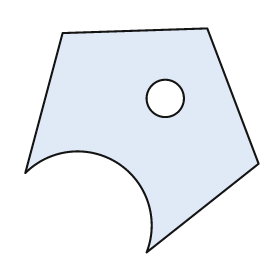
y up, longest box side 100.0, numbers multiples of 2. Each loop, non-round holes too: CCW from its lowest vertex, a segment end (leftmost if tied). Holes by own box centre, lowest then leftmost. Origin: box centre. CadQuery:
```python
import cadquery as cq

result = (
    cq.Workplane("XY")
    .moveTo(2.0, -48.0)
    .lineTo(50.0, -10.0)
    .lineTo(28.0, 48.0)
    .lineTo(-34.0, 46.0)
    .lineTo(-50.0, -14.0)
    .threePointArc((-10.0, -10.0), (2.0, -48.0))
    .close()
    .moveTo(10.0, 18.0)
    .circle(8.0)
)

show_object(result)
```